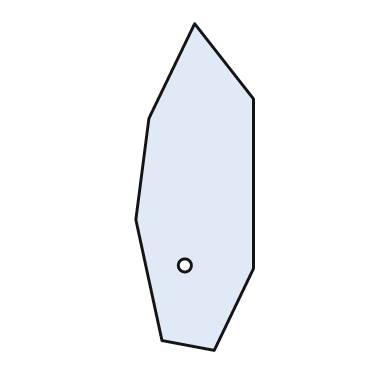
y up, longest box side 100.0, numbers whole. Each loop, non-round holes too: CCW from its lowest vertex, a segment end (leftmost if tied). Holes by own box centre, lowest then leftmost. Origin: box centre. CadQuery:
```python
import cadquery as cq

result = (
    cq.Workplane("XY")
    .moveTo(6.0, -50.0)
    .lineTo(18.0, -25.0)
    .lineTo(18.0, 27.0)
    .lineTo(0.0, 50.0)
    .lineTo(-14.0, 21.0)
    .lineTo(-18.0, -10.0)
    .lineTo(-10.0, -47.0)
    .close()
    .moveTo(-3.0, -24.0)
    .circle(2.0)
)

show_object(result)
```